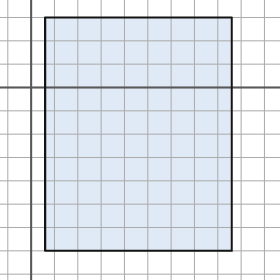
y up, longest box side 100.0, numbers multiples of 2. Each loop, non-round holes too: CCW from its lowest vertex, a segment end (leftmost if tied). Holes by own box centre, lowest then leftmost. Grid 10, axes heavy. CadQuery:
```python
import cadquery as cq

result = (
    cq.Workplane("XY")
    .moveTo(6.0, -70.0)
    .lineTo(86.0, -70.0)
    .lineTo(86.0, 30.0)
    .lineTo(6.0, 30.0)
    .close()
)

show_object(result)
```